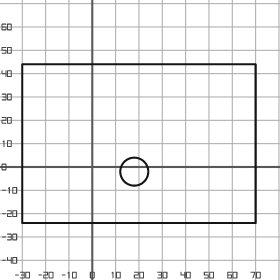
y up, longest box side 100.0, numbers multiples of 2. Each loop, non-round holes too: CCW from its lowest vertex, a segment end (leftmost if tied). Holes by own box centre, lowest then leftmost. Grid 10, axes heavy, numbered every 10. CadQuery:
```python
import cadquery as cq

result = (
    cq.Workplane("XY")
    .moveTo(-30.0, -24.0)
    .lineTo(70.0, -24.0)
    .lineTo(70.0, 44.0)
    .lineTo(-30.0, 44.0)
    .close()
    .moveTo(18.0, -2.0)
    .circle(6.0)
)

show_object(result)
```